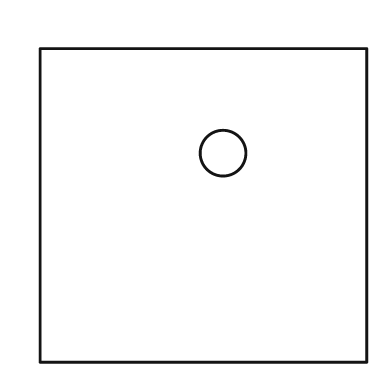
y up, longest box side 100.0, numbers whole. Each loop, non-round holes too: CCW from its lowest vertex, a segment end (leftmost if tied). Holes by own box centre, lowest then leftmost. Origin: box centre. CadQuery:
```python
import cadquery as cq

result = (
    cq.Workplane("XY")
    .moveTo(-50.0, -48.0)
    .lineTo(50.0, -48.0)
    .lineTo(50.0, 48.0)
    .lineTo(-50.0, 48.0)
    .close()
    .moveTo(6.0, 16.0)
    .circle(7.0)
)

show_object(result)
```